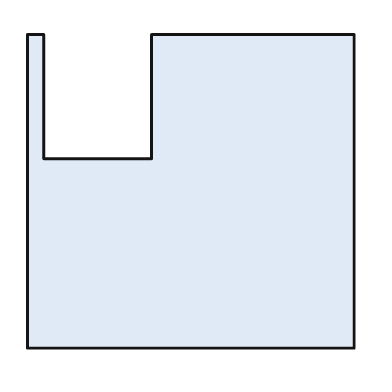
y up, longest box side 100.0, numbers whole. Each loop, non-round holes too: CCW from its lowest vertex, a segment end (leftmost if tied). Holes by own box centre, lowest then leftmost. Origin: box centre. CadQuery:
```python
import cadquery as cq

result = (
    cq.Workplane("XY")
    .moveTo(-50.0, -48.0)
    .lineTo(50.0, -48.0)
    .lineTo(50.0, 48.0)
    .lineTo(-12.0, 48.0)
    .lineTo(-12.0, 10.0)
    .lineTo(-45.0, 10.0)
    .lineTo(-45.0, 48.0)
    .lineTo(-50.0, 48.0)
    .close()
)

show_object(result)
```